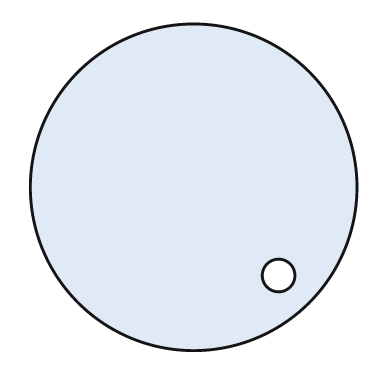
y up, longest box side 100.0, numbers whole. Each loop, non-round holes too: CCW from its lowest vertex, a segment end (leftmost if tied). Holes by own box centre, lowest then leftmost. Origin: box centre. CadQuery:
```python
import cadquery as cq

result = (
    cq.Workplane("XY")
    .moveTo(0.0, 0.0)
    .circle(50.0)
    .moveTo(26.0, -27.0)
    .circle(5.0)
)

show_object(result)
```